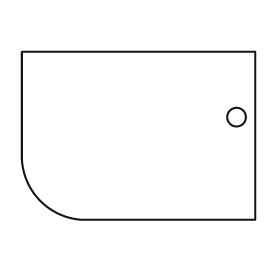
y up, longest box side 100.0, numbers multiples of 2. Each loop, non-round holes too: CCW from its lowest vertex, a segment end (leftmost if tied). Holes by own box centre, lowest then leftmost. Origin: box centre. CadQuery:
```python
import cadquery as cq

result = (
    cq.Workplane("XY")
    .moveTo(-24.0, -36.0)
    .lineTo(50.0, -36.0)
    .lineTo(50.0, 36.0)
    .lineTo(-50.0, 36.0)
    .lineTo(-50.0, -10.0)
    .threePointArc((-42.0, -28.0), (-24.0, -36.0))
    .close()
    .moveTo(42.0, 8.0)
    .circle(4.0)
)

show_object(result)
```